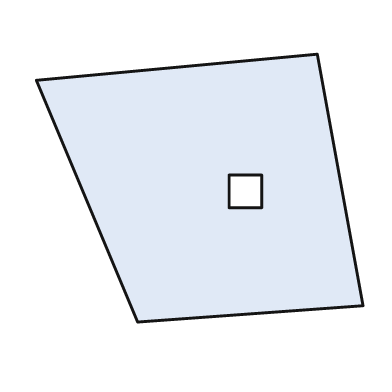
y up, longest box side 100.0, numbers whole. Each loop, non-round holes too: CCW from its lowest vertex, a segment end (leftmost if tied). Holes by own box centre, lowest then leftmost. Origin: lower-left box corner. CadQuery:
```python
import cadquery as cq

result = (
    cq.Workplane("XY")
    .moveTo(31.0, 0.0)
    .lineTo(100.0, 5.0)
    .lineTo(86.0, 82.0)
    .lineTo(0.0, 74.0)
    .close()
    .moveTo(59.0, 35.0)
    .lineTo(69.0, 35.0)
    .lineTo(69.0, 45.0)
    .lineTo(59.0, 45.0)
    .close()
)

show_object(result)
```